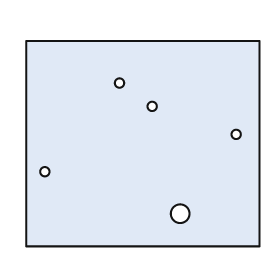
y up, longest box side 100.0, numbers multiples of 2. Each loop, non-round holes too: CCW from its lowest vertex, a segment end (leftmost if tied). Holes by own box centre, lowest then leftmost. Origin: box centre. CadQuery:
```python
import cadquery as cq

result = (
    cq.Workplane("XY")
    .moveTo(-50.0, -44.0)
    .lineTo(50.0, -44.0)
    .lineTo(50.0, 44.0)
    .lineTo(-50.0, 44.0)
    .close()
    .moveTo(16.0, -30.0)
    .circle(4.0)
    .moveTo(-42.0, -12.0)
    .circle(2.0)
    .moveTo(40.0, 4.0)
    .circle(2.0)
    .moveTo(4.0, 16.0)
    .circle(2.0)
    .moveTo(-10.0, 26.0)
    .circle(2.0)
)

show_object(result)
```